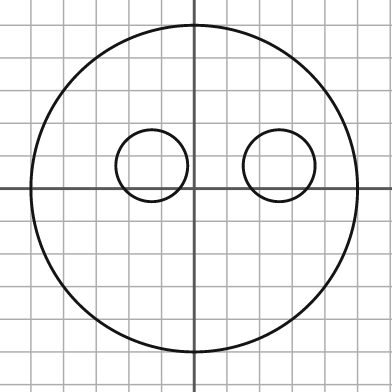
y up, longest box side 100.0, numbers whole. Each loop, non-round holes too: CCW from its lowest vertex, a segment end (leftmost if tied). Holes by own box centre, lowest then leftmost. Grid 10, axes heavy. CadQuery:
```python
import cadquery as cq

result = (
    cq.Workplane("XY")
    .moveTo(0.0, 0.0)
    .circle(50.0)
    .moveTo(-13.0, 7.0)
    .circle(11.0)
    .moveTo(26.0, 7.0)
    .circle(11.0)
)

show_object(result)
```